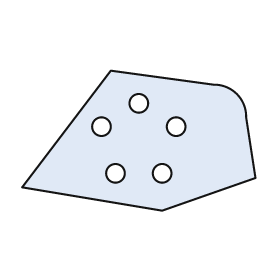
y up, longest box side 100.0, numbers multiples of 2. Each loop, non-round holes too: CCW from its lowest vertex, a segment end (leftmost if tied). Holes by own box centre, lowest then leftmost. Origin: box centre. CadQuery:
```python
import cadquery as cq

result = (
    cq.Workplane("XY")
    .moveTo(10.0, -30.0)
    .lineTo(50.0, -16.0)
    .lineTo(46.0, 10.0)
    .threePointArc((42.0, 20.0), (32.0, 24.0))
    .lineTo(-12.0, 30.0)
    .lineTo(-50.0, -20.0)
    .close()
    .moveTo(-10.0, -14.0)
    .circle(4.0)
    .moveTo(10.0, -14.0)
    .circle(4.0)
    .moveTo(-16.0, 6.0)
    .circle(4.0)
    .moveTo(16.0, 6.0)
    .circle(4.0)
    .moveTo(0.0, 16.0)
    .circle(4.0)
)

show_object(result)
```